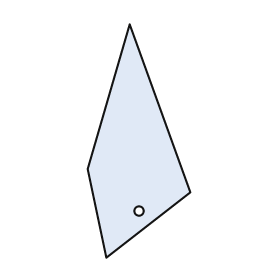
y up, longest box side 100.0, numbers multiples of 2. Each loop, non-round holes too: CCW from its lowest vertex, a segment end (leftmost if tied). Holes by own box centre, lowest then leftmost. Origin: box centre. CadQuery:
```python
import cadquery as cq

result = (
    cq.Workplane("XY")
    .moveTo(-14.0, -50.0)
    .lineTo(22.0, -22.0)
    .lineTo(-4.0, 50.0)
    .lineTo(-22.0, -12.0)
    .close()
    .moveTo(0.0, -30.0)
    .circle(2.0)
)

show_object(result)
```